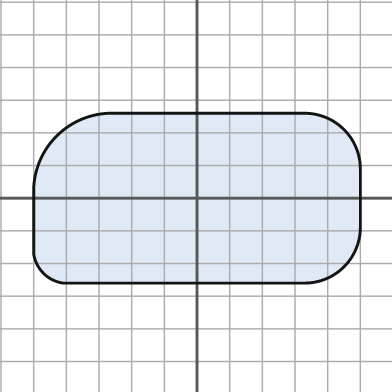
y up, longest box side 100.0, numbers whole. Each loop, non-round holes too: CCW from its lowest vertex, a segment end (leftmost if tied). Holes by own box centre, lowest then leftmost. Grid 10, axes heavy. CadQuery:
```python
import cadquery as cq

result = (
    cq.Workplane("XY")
    .moveTo(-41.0, -26.0)
    .lineTo(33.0, -26.0)
    .threePointArc((45.0, -21.0), (50.0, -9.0))
    .lineTo(50.0, 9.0)
    .threePointArc((45.0, 21.0), (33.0, 26.0))
    .lineTo(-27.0, 26.0)
    .threePointArc((-43.0, 19.0), (-50.0, 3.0))
    .lineTo(-50.0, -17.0)
    .threePointArc((-47.0, -23.0), (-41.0, -26.0))
    .close()
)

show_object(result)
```